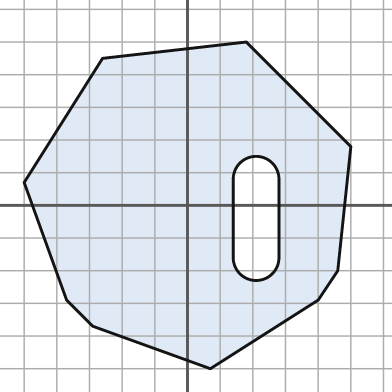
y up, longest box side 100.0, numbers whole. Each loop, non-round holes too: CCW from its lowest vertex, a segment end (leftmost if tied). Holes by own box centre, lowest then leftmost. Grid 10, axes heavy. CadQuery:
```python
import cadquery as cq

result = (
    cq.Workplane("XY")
    .moveTo(7.0, -50.0)
    .lineTo(40.0, -29.0)
    .lineTo(46.0, -20.0)
    .lineTo(50.0, 18.0)
    .lineTo(18.0, 50.0)
    .lineTo(-26.0, 45.0)
    .lineTo(-50.0, 7.0)
    .lineTo(-37.0, -29.0)
    .lineTo(-29.0, -37.0)
    .close()
    .moveTo(14.0, -16.0)
    .threePointArc((21.0, -23.0), (28.0, -16.0))
    .lineTo(28.0, 8.0)
    .threePointArc((21.0, 15.0), (14.0, 8.0))
    .close()
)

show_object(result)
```